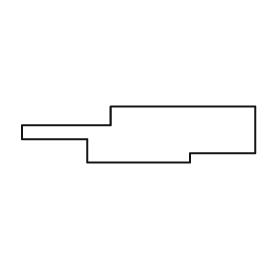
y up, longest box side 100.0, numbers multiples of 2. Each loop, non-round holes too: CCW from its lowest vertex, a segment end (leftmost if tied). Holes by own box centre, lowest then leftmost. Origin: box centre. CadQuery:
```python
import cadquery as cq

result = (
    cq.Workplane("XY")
    .moveTo(-22.0, -12.0)
    .lineTo(22.0, -12.0)
    .lineTo(22.0, -8.0)
    .lineTo(50.0, -8.0)
    .lineTo(50.0, 12.0)
    .lineTo(-12.0, 12.0)
    .lineTo(-12.0, 4.0)
    .lineTo(-50.0, 4.0)
    .lineTo(-50.0, -2.0)
    .lineTo(-22.0, -2.0)
    .close()
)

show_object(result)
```